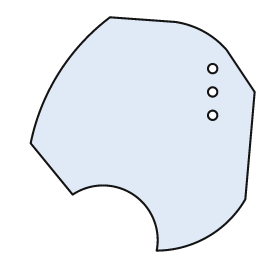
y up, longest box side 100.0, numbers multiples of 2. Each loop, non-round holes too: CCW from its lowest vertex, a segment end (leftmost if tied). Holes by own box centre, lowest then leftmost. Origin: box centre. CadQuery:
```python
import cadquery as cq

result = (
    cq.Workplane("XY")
    .moveTo(6.0, -50.0)
    .threePointArc((28.0, -44.0), (44.0, -28.0))
    .lineTo(48.0, 18.0)
    .lineTo(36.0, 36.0)
    .threePointArc((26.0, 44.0), (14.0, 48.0))
    .lineTo(-14.0, 50.0)
    .threePointArc((-36.0, 26.0), (-48.0, -4.0))
    .lineTo(-30.0, -26.0)
    .threePointArc((-4.0, -26.0), (6.0, -50.0))
    .close()
    .moveTo(30.0, 8.0)
    .circle(2.0)
    .moveTo(30.0, 18.0)
    .circle(2.0)
    .moveTo(30.0, 28.0)
    .circle(2.0)
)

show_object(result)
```